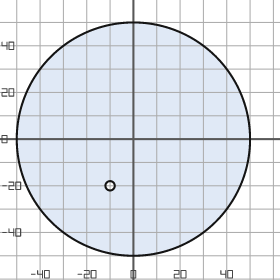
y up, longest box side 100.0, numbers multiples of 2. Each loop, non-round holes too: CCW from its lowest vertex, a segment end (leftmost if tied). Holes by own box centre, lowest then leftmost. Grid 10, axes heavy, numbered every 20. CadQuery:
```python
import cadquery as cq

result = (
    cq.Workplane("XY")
    .moveTo(0.0, 0.0)
    .circle(50.0)
    .moveTo(-10.0, -20.0)
    .circle(2.0)
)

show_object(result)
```